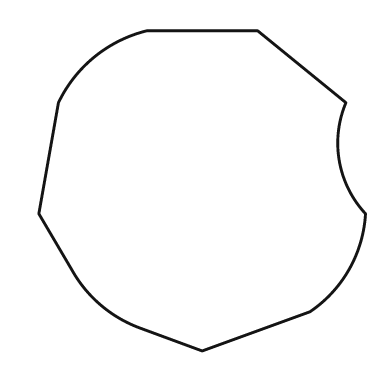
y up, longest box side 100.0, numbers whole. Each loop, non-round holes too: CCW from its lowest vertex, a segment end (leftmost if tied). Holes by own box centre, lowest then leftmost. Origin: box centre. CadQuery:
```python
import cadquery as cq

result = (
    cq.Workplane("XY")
    .moveTo(0.0, -49.0)
    .lineTo(33.0, -37.0)
    .threePointArc((45.0, -24.0), (50.0, -7.0))
    .threePointArc((42.0, 9.0), (44.0, 27.0))
    .lineTo(17.0, 49.0)
    .lineTo(-17.0, 49.0)
    .threePointArc((-33.0, 41.0), (-44.0, 27.0))
    .lineTo(-50.0, -7.0)
    .lineTo(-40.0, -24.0)
    .threePointArc((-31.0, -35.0), (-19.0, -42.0))
    .close()
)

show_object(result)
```